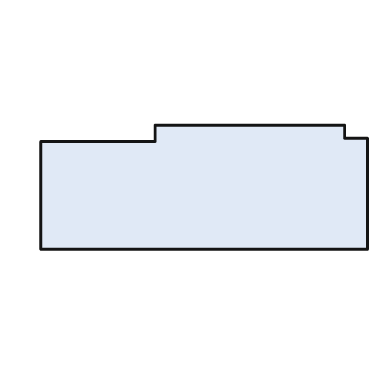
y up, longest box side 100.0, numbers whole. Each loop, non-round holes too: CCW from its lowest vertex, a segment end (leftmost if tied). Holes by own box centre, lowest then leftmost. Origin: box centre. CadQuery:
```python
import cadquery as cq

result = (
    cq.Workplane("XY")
    .moveTo(-50.0, -19.0)
    .lineTo(50.0, -19.0)
    .lineTo(50.0, 15.0)
    .lineTo(43.0, 15.0)
    .lineTo(43.0, 19.0)
    .lineTo(-15.0, 19.0)
    .lineTo(-15.0, 14.0)
    .lineTo(-50.0, 14.0)
    .close()
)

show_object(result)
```